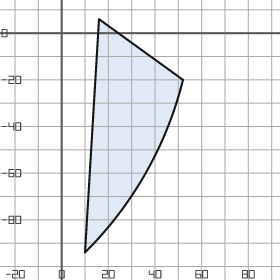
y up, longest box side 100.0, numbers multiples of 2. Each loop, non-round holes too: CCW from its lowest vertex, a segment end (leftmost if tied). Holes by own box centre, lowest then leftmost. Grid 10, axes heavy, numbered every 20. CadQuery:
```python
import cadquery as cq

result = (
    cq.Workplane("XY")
    .moveTo(10.0, -94.0)
    .threePointArc((36.0, -60.0), (52.0, -20.0))
    .lineTo(16.0, 6.0)
    .close()
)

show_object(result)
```